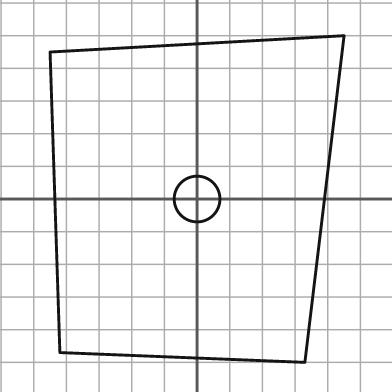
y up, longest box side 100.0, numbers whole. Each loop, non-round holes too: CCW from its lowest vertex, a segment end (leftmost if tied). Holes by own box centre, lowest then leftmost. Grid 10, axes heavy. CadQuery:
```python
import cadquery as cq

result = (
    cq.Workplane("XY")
    .moveTo(33.0, -50.0)
    .lineTo(45.0, 50.0)
    .lineTo(-45.0, 45.0)
    .lineTo(-42.0, -47.0)
    .close()
    .moveTo(0.0, 0.0)
    .circle(7.0)
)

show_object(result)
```